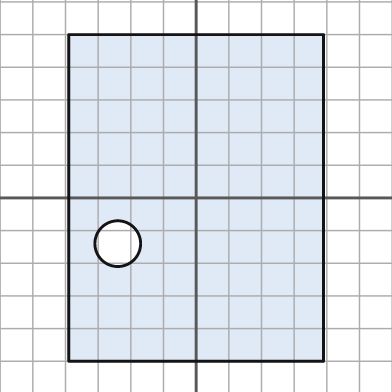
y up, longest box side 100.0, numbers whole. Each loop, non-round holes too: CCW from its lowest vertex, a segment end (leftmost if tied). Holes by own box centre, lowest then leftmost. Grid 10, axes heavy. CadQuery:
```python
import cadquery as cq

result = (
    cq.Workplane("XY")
    .moveTo(-39.0, -50.0)
    .lineTo(39.0, -50.0)
    .lineTo(39.0, 50.0)
    .lineTo(-39.0, 50.0)
    .close()
    .moveTo(-24.0, -14.0)
    .circle(7.0)
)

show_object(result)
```